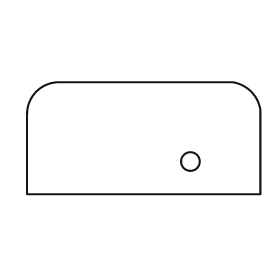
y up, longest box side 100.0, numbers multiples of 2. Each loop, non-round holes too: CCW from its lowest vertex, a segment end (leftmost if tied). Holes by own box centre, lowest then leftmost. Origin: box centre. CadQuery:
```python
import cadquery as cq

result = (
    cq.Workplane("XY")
    .moveTo(-50.0, -24.0)
    .lineTo(50.0, -24.0)
    .lineTo(50.0, 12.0)
    .threePointArc((46.0, 20.0), (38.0, 24.0))
    .lineTo(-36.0, 24.0)
    .threePointArc((-46.0, 20.0), (-50.0, 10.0))
    .close()
    .moveTo(20.0, -10.0)
    .circle(4.0)
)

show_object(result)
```